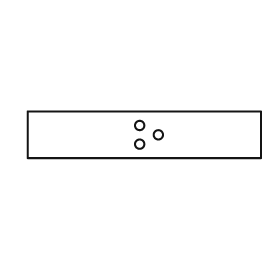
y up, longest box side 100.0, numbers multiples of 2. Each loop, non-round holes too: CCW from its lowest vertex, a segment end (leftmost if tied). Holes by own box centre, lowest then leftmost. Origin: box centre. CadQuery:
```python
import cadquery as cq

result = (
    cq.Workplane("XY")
    .moveTo(-50.0, -10.0)
    .lineTo(50.0, -10.0)
    .lineTo(50.0, 10.0)
    .lineTo(-50.0, 10.0)
    .close()
    .moveTo(-2.0, -4.0)
    .circle(2.0)
    .moveTo(6.0, 0.0)
    .circle(2.0)
    .moveTo(-2.0, 4.0)
    .circle(2.0)
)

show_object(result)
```